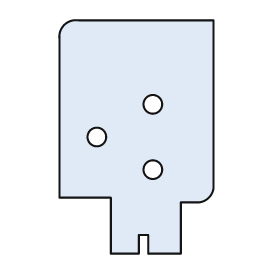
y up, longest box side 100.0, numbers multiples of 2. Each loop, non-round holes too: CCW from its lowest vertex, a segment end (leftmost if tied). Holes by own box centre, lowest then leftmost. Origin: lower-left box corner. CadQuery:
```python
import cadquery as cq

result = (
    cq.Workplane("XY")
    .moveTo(22.0, 0.0)
    .lineTo(34.0, 0.0)
    .lineTo(34.0, 8.0)
    .lineTo(38.0, 8.0)
    .lineTo(38.0, 0.0)
    .lineTo(52.0, 0.0)
    .lineTo(52.0, 22.0)
    .lineTo(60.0, 22.0)
    .threePointArc((64.0, 24.0), (66.0, 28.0))
    .lineTo(66.0, 100.0)
    .lineTo(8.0, 100.0)
    .threePointArc((2.0, 98.0), (0.0, 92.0))
    .lineTo(0.0, 24.0)
    .lineTo(22.0, 24.0)
    .close()
    .moveTo(40.0, 36.0)
    .circle(4.0)
    .moveTo(16.0, 50.0)
    .circle(4.0)
    .moveTo(40.0, 64.0)
    .circle(4.0)
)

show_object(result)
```